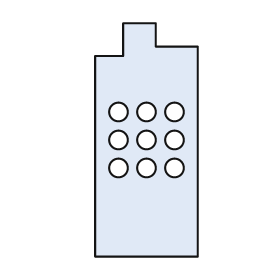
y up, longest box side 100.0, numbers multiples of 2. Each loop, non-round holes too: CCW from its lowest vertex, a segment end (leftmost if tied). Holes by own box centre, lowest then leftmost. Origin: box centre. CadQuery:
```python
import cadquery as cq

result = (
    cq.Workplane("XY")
    .moveTo(-22.0, -50.0)
    .lineTo(22.0, -50.0)
    .lineTo(22.0, 40.0)
    .lineTo(4.0, 40.0)
    .lineTo(4.0, 50.0)
    .lineTo(-10.0, 50.0)
    .lineTo(-10.0, 36.0)
    .lineTo(-22.0, 36.0)
    .close()
    .moveTo(-12.0, -12.0)
    .circle(4.0)
    .moveTo(0.0, -12.0)
    .circle(4.0)
    .moveTo(12.0, -12.0)
    .circle(4.0)
    .moveTo(-12.0, 0.0)
    .circle(4.0)
    .moveTo(0.0, 0.0)
    .circle(4.0)
    .moveTo(12.0, 0.0)
    .circle(4.0)
    .moveTo(-12.0, 12.0)
    .circle(4.0)
    .moveTo(0.0, 12.0)
    .circle(4.0)
    .moveTo(12.0, 12.0)
    .circle(4.0)
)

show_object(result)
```